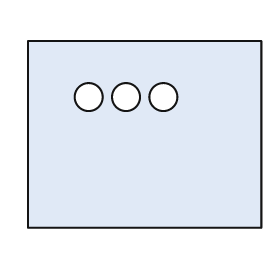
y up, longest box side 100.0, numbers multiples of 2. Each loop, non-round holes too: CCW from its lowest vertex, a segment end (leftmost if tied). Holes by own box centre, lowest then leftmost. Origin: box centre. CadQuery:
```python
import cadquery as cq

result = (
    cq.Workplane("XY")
    .moveTo(-50.0, -40.0)
    .lineTo(50.0, -40.0)
    .lineTo(50.0, 40.0)
    .lineTo(-50.0, 40.0)
    .close()
    .moveTo(-24.0, 16.0)
    .circle(6.0)
    .moveTo(-8.0, 16.0)
    .circle(6.0)
    .moveTo(8.0, 16.0)
    .circle(6.0)
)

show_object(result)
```